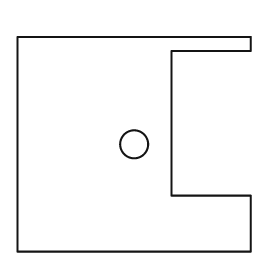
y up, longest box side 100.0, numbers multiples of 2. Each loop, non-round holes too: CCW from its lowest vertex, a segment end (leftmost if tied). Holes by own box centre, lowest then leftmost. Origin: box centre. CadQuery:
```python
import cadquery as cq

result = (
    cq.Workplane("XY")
    .moveTo(-50.0, -46.0)
    .lineTo(50.0, -46.0)
    .lineTo(50.0, -22.0)
    .lineTo(16.0, -22.0)
    .lineTo(16.0, 40.0)
    .lineTo(50.0, 40.0)
    .lineTo(50.0, 46.0)
    .lineTo(-50.0, 46.0)
    .close()
    .moveTo(0.0, 0.0)
    .circle(6.0)
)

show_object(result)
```